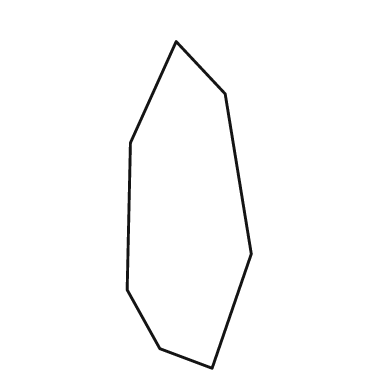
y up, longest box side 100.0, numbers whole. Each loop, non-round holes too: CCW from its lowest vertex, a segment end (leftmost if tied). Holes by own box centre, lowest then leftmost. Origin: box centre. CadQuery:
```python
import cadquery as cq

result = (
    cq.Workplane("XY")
    .moveTo(7.0, -50.0)
    .lineTo(19.0, -15.0)
    .lineTo(11.0, 34.0)
    .lineTo(-4.0, 50.0)
    .lineTo(-18.0, 19.0)
    .lineTo(-19.0, -26.0)
    .lineTo(-9.0, -44.0)
    .close()
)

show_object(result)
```